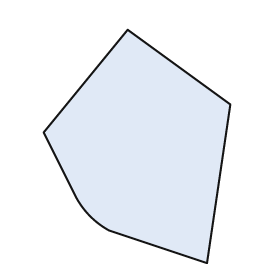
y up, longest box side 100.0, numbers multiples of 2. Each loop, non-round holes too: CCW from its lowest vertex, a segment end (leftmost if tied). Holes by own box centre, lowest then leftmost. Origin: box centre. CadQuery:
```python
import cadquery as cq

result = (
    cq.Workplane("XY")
    .moveTo(30.0, -50.0)
    .lineTo(40.0, 18.0)
    .lineTo(-4.0, 50.0)
    .lineTo(-40.0, 6.0)
    .lineTo(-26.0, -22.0)
    .threePointArc((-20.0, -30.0), (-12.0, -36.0))
    .close()
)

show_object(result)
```